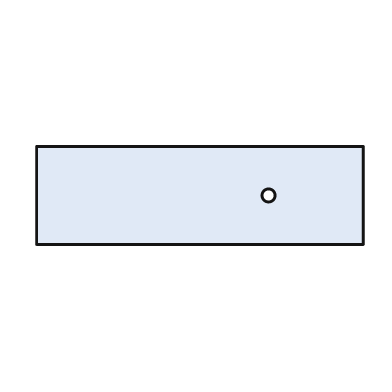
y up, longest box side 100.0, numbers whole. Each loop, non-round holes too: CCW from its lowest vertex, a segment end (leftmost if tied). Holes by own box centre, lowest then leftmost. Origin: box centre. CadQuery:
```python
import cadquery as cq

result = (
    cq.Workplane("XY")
    .moveTo(-50.0, -15.0)
    .lineTo(50.0, -15.0)
    .lineTo(50.0, 15.0)
    .lineTo(-50.0, 15.0)
    .close()
    .moveTo(21.0, 0.0)
    .circle(2.0)
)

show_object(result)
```